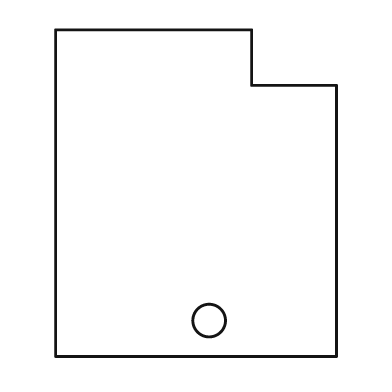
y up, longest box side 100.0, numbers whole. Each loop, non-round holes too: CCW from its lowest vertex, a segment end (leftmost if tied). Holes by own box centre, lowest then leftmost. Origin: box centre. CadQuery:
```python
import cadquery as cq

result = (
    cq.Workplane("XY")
    .moveTo(-43.0, -50.0)
    .lineTo(43.0, -50.0)
    .lineTo(43.0, 33.0)
    .lineTo(17.0, 33.0)
    .lineTo(17.0, 50.0)
    .lineTo(-43.0, 50.0)
    .close()
    .moveTo(4.0, -39.0)
    .circle(5.0)
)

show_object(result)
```